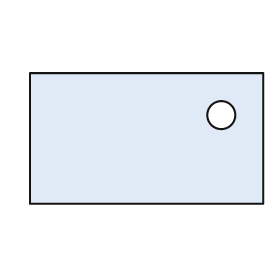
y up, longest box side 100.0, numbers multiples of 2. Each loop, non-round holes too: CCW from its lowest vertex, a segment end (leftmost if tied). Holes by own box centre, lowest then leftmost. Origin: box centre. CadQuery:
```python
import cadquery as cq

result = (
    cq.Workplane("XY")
    .moveTo(-50.0, -28.0)
    .lineTo(50.0, -28.0)
    .lineTo(50.0, 28.0)
    .lineTo(-50.0, 28.0)
    .close()
    .moveTo(32.0, 10.0)
    .circle(6.0)
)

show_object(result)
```